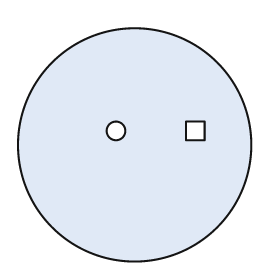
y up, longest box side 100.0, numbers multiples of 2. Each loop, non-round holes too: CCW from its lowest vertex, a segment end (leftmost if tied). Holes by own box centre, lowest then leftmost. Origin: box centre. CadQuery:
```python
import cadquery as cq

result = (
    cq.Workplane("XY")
    .moveTo(0.0, 0.0)
    .circle(50.0)
    .moveTo(-8.0, 6.0)
    .circle(4.0)
    .moveTo(22.0, 2.0)
    .lineTo(30.0, 2.0)
    .lineTo(30.0, 10.0)
    .lineTo(22.0, 10.0)
    .close()
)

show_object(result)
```